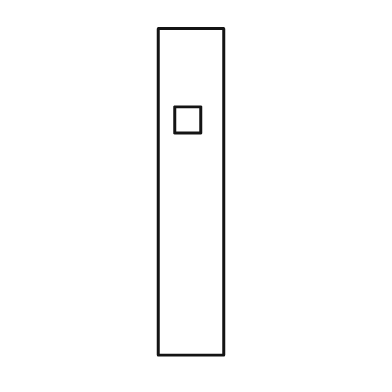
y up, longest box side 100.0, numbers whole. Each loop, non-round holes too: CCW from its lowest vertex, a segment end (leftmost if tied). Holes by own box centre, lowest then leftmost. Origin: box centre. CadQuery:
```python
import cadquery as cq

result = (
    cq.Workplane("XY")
    .moveTo(-10.0, -50.0)
    .lineTo(10.0, -50.0)
    .lineTo(10.0, 50.0)
    .lineTo(-10.0, 50.0)
    .close()
    .moveTo(-5.0, 18.0)
    .lineTo(3.0, 18.0)
    .lineTo(3.0, 26.0)
    .lineTo(-5.0, 26.0)
    .close()
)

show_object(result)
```